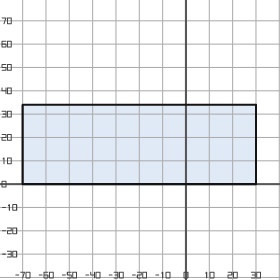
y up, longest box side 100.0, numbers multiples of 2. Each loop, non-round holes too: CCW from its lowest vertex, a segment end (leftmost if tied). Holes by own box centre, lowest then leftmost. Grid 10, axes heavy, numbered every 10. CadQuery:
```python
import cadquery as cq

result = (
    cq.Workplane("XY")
    .moveTo(-70.0, 0.0)
    .lineTo(30.0, 0.0)
    .lineTo(30.0, 34.0)
    .lineTo(-70.0, 34.0)
    .close()
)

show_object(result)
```